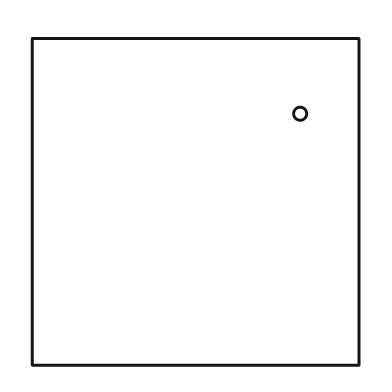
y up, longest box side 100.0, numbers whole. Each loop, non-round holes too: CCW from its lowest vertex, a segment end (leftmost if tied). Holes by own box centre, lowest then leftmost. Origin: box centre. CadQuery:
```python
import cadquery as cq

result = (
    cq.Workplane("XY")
    .moveTo(-50.0, -50.0)
    .lineTo(50.0, -50.0)
    .lineTo(50.0, 50.0)
    .lineTo(-50.0, 50.0)
    .close()
    .moveTo(32.0, 27.0)
    .circle(2.0)
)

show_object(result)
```